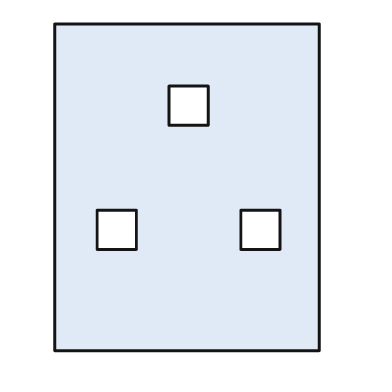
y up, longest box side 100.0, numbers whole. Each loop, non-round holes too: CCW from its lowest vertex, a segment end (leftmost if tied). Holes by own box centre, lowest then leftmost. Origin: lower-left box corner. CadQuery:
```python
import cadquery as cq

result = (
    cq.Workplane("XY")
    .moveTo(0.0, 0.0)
    .lineTo(81.0, 0.0)
    .lineTo(81.0, 100.0)
    .lineTo(0.0, 100.0)
    .close()
    .moveTo(13.0, 31.0)
    .lineTo(25.0, 31.0)
    .lineTo(25.0, 43.0)
    .lineTo(13.0, 43.0)
    .close()
    .moveTo(57.0, 31.0)
    .lineTo(69.0, 31.0)
    .lineTo(69.0, 43.0)
    .lineTo(57.0, 43.0)
    .close()
    .moveTo(35.0, 69.0)
    .lineTo(47.0, 69.0)
    .lineTo(47.0, 81.0)
    .lineTo(35.0, 81.0)
    .close()
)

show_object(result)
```